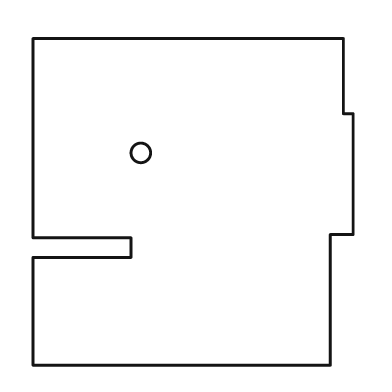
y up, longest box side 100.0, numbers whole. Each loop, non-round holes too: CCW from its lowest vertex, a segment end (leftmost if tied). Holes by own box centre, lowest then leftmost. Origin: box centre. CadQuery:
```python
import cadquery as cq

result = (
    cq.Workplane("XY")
    .moveTo(-49.0, -50.0)
    .lineTo(42.0, -50.0)
    .lineTo(42.0, -10.0)
    .lineTo(49.0, -10.0)
    .lineTo(49.0, 27.0)
    .lineTo(46.0, 27.0)
    .lineTo(46.0, 50.0)
    .lineTo(-49.0, 50.0)
    .lineTo(-49.0, -11.0)
    .lineTo(-19.0, -11.0)
    .lineTo(-19.0, -17.0)
    .lineTo(-49.0, -17.0)
    .close()
    .moveTo(-16.0, 15.0)
    .circle(3.0)
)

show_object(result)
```